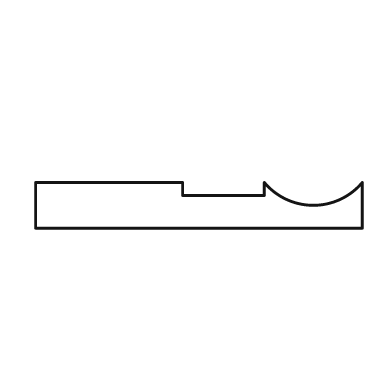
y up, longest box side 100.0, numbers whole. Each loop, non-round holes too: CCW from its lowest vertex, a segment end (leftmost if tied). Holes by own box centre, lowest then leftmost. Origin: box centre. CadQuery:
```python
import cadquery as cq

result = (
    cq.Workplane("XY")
    .moveTo(-50.0, -7.0)
    .lineTo(50.0, -7.0)
    .lineTo(50.0, 7.0)
    .threePointArc((35.0, 0.0), (20.0, 7.0))
    .lineTo(20.0, 3.0)
    .lineTo(-5.0, 3.0)
    .lineTo(-5.0, 7.0)
    .lineTo(-50.0, 7.0)
    .close()
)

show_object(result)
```